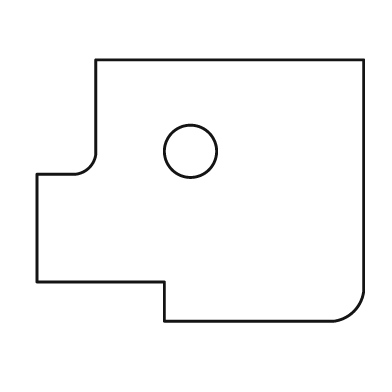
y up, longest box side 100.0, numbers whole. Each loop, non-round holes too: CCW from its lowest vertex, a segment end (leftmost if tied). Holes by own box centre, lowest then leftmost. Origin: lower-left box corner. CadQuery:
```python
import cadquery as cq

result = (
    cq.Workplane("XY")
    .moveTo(39.0, 0.0)
    .lineTo(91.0, 0.0)
    .threePointArc((97.0, 3.0), (100.0, 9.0))
    .lineTo(100.0, 80.0)
    .lineTo(18.0, 80.0)
    .lineTo(18.0, 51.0)
    .threePointArc((16.0, 47.0), (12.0, 45.0))
    .lineTo(0.0, 45.0)
    .lineTo(0.0, 12.0)
    .lineTo(39.0, 12.0)
    .close()
    .moveTo(47.0, 52.0)
    .circle(8.0)
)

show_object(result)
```